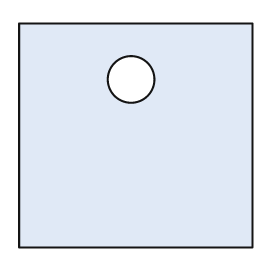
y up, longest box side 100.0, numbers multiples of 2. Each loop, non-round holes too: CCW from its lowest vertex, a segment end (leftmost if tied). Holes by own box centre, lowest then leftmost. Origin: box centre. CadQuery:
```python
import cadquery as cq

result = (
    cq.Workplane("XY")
    .moveTo(-50.0, -48.0)
    .lineTo(50.0, -48.0)
    .lineTo(50.0, 48.0)
    .lineTo(-50.0, 48.0)
    .close()
    .moveTo(-2.0, 24.0)
    .circle(10.0)
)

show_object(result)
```